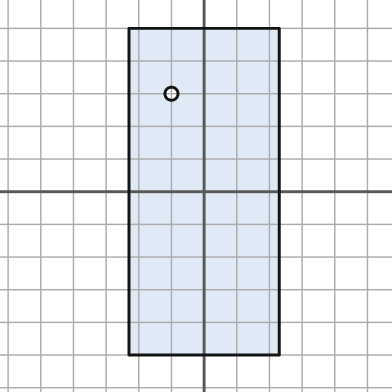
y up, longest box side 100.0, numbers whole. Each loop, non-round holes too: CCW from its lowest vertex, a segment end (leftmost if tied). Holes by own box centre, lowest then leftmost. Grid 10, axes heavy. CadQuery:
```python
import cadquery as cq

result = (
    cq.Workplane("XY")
    .moveTo(-23.0, -50.0)
    .lineTo(23.0, -50.0)
    .lineTo(23.0, 50.0)
    .lineTo(-23.0, 50.0)
    .close()
    .moveTo(-10.0, 30.0)
    .circle(2.0)
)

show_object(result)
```